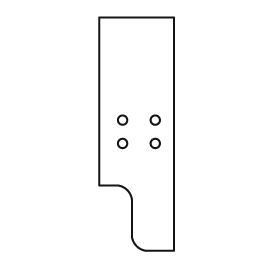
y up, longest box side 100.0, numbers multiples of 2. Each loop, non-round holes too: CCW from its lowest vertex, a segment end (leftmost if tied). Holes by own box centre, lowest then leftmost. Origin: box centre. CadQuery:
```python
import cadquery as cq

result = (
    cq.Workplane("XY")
    .moveTo(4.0, -50.0)
    .lineTo(16.0, -50.0)
    .lineTo(16.0, 50.0)
    .lineTo(-16.0, 50.0)
    .lineTo(-16.0, -22.0)
    .lineTo(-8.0, -22.0)
    .threePointArc((-4.0, -24.0), (-2.0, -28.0))
    .lineTo(-2.0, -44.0)
    .threePointArc((0.0, -48.0), (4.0, -50.0))
    .close()
    .moveTo(-6.0, -4.0)
    .circle(2.0)
    .moveTo(8.0, -4.0)
    .circle(2.0)
    .moveTo(-6.0, 6.0)
    .circle(2.0)
    .moveTo(8.0, 6.0)
    .circle(2.0)
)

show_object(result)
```